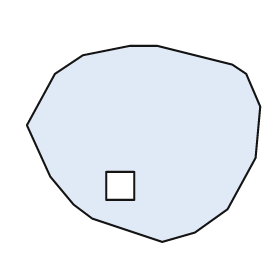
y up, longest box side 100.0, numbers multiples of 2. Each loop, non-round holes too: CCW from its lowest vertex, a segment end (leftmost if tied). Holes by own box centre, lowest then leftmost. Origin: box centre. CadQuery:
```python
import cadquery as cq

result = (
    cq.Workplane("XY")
    .moveTo(8.0, -42.0)
    .lineTo(22.0, -38.0)
    .lineTo(36.0, -28.0)
    .lineTo(48.0, -6.0)
    .lineTo(50.0, 16.0)
    .lineTo(44.0, 30.0)
    .lineTo(38.0, 34.0)
    .lineTo(6.0, 42.0)
    .lineTo(-6.0, 42.0)
    .lineTo(-26.0, 38.0)
    .lineTo(-38.0, 30.0)
    .lineTo(-50.0, 8.0)
    .lineTo(-40.0, -14.0)
    .lineTo(-30.0, -26.0)
    .lineTo(-22.0, -32.0)
    .close()
    .moveTo(-16.0, -24.0)
    .lineTo(-4.0, -24.0)
    .lineTo(-4.0, -12.0)
    .lineTo(-16.0, -12.0)
    .close()
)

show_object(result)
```